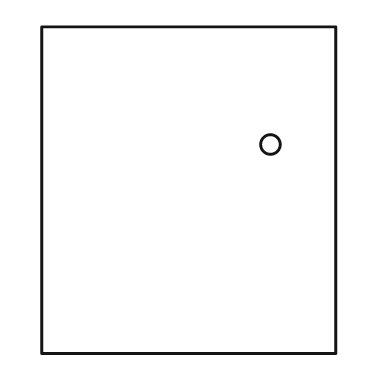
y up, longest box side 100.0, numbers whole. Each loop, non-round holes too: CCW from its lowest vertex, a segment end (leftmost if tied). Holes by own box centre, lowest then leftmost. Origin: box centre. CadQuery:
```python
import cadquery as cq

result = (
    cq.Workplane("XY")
    .moveTo(-45.0, -50.0)
    .lineTo(45.0, -50.0)
    .lineTo(45.0, 50.0)
    .lineTo(-45.0, 50.0)
    .close()
    .moveTo(25.0, 14.0)
    .circle(3.0)
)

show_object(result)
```